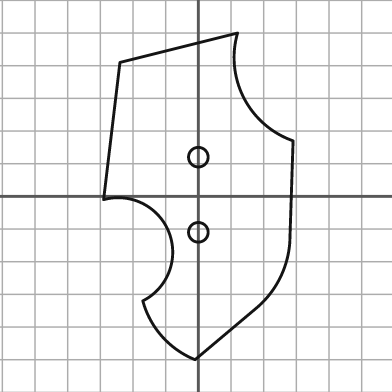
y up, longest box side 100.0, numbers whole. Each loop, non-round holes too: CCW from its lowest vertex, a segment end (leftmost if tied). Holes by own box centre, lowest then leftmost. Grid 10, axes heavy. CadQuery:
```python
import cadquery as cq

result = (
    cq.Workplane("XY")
    .moveTo(-1.0, -50.0)
    .lineTo(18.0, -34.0)
    .threePointArc((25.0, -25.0), (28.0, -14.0))
    .lineTo(29.0, 17.0)
    .threePointArc((14.0, 30.0), (12.0, 50.0))
    .lineTo(-24.0, 41.0)
    .lineTo(-29.0, -1.0)
    .threePointArc((-9.0, -11.0), (-17.0, -32.0))
    .threePointArc((-11.0, -43.0), (-1.0, -50.0))
    .close()
    .moveTo(0.0, -11.0)
    .circle(3.0)
    .moveTo(0.0, 12.0)
    .circle(3.0)
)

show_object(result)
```